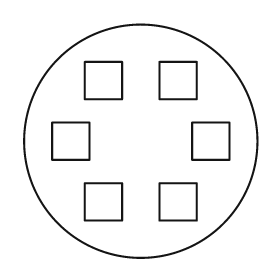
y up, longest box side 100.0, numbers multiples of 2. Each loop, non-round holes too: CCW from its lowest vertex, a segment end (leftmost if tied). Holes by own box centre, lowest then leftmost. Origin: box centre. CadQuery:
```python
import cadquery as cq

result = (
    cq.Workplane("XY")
    .moveTo(0.0, 0.0)
    .circle(50.0)
    .moveTo(-24.0, -34.0)
    .lineTo(-8.0, -34.0)
    .lineTo(-8.0, -18.0)
    .lineTo(-24.0, -18.0)
    .close()
    .moveTo(8.0, -34.0)
    .lineTo(24.0, -34.0)
    .lineTo(24.0, -18.0)
    .lineTo(8.0, -18.0)
    .close()
    .moveTo(-38.0, -8.0)
    .lineTo(-22.0, -8.0)
    .lineTo(-22.0, 8.0)
    .lineTo(-38.0, 8.0)
    .close()
    .moveTo(22.0, -8.0)
    .lineTo(38.0, -8.0)
    .lineTo(38.0, 8.0)
    .lineTo(22.0, 8.0)
    .close()
    .moveTo(-24.0, 18.0)
    .lineTo(-8.0, 18.0)
    .lineTo(-8.0, 34.0)
    .lineTo(-24.0, 34.0)
    .close()
    .moveTo(8.0, 18.0)
    .lineTo(24.0, 18.0)
    .lineTo(24.0, 34.0)
    .lineTo(8.0, 34.0)
    .close()
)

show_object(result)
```